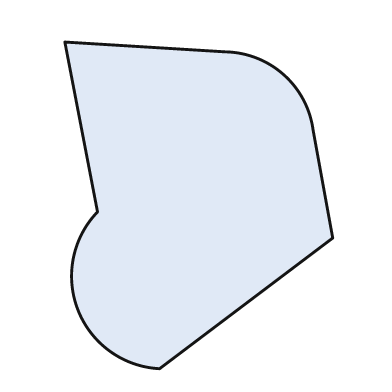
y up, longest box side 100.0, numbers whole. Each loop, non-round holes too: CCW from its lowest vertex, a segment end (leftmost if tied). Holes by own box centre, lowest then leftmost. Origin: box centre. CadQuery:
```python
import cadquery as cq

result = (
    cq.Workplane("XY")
    .moveTo(-12.0, -50.0)
    .lineTo(41.0, -10.0)
    .lineTo(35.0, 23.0)
    .threePointArc((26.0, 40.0), (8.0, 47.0))
    .lineTo(-41.0, 50.0)
    .lineTo(-31.0, -2.0)
    .threePointArc((-37.0, -32.0), (-12.0, -50.0))
    .close()
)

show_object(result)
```